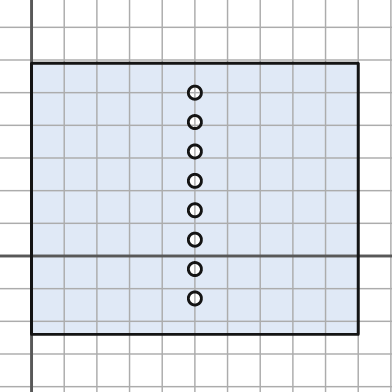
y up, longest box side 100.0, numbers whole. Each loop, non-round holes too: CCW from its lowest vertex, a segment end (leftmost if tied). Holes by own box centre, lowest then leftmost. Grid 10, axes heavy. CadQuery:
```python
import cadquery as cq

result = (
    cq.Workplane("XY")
    .moveTo(0.0, -24.0)
    .lineTo(100.0, -24.0)
    .lineTo(100.0, 59.0)
    .lineTo(0.0, 59.0)
    .close()
    .moveTo(50.0, -13.0)
    .circle(2.0)
    .moveTo(50.0, -4.0)
    .circle(2.0)
    .moveTo(50.0, 5.0)
    .circle(2.0)
    .moveTo(50.0, 14.0)
    .circle(2.0)
    .moveTo(50.0, 23.0)
    .circle(2.0)
    .moveTo(50.0, 32.0)
    .circle(2.0)
    .moveTo(50.0, 41.0)
    .circle(2.0)
    .moveTo(50.0, 50.0)
    .circle(2.0)
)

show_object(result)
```